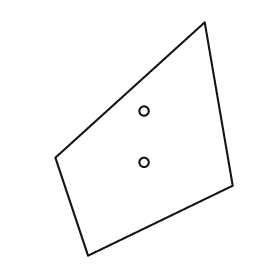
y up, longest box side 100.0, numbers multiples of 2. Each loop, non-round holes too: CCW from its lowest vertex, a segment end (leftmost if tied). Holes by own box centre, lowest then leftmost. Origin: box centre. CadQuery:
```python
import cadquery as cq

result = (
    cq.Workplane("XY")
    .moveTo(-24.0, -50.0)
    .lineTo(38.0, -20.0)
    .lineTo(26.0, 50.0)
    .lineTo(-38.0, -8.0)
    .close()
    .moveTo(0.0, -10.0)
    .circle(2.0)
    .moveTo(0.0, 12.0)
    .circle(2.0)
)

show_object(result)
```